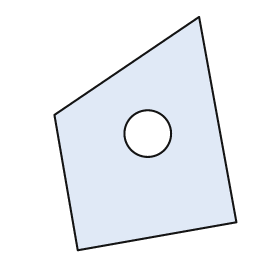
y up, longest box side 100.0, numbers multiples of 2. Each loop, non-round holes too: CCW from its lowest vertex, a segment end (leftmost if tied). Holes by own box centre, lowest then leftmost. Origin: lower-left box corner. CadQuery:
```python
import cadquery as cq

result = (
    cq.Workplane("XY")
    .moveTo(10.0, 0.0)
    .lineTo(78.0, 12.0)
    .lineTo(62.0, 100.0)
    .lineTo(0.0, 58.0)
    .close()
    .moveTo(40.0, 50.0)
    .circle(10.0)
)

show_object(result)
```